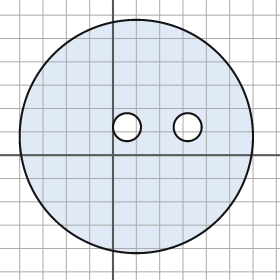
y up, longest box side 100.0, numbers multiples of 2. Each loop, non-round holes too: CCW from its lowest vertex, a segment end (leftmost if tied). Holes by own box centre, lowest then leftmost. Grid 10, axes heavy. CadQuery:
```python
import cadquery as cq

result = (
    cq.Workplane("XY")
    .moveTo(10.0, 8.0)
    .circle(50.0)
    .moveTo(6.0, 12.0)
    .circle(6.0)
    .moveTo(32.0, 12.0)
    .circle(6.0)
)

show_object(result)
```